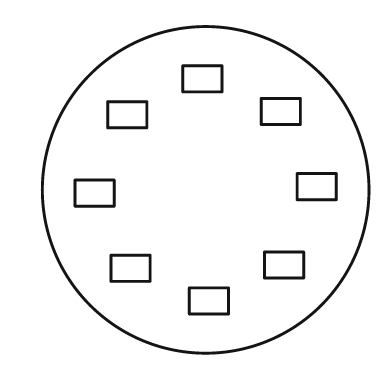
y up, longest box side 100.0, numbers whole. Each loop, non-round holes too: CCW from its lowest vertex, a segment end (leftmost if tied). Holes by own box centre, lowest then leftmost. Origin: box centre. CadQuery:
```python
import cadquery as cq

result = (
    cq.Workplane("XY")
    .moveTo(0.0, 0.0)
    .circle(50.0)
    .moveTo(-5.0, -38.0)
    .lineTo(7.0, -38.0)
    .lineTo(7.0, -30.0)
    .lineTo(-5.0, -30.0)
    .close()
    .moveTo(-29.0, -28.0)
    .lineTo(-17.0, -28.0)
    .lineTo(-17.0, -20.0)
    .lineTo(-29.0, -20.0)
    .close()
    .moveTo(18.0, -27.0)
    .lineTo(30.0, -27.0)
    .lineTo(30.0, -19.0)
    .lineTo(18.0, -19.0)
    .close()
    .moveTo(-40.0, -5.0)
    .lineTo(-28.0, -5.0)
    .lineTo(-28.0, 3.0)
    .lineTo(-40.0, 3.0)
    .close()
    .moveTo(28.0, -3.0)
    .lineTo(40.0, -3.0)
    .lineTo(40.0, 5.0)
    .lineTo(28.0, 5.0)
    .close()
    .moveTo(-30.0, 19.0)
    .lineTo(-18.0, 19.0)
    .lineTo(-18.0, 27.0)
    .lineTo(-30.0, 27.0)
    .close()
    .moveTo(17.0, 20.0)
    .lineTo(29.0, 20.0)
    .lineTo(29.0, 28.0)
    .lineTo(17.0, 28.0)
    .close()
    .moveTo(-7.0, 30.0)
    .lineTo(5.0, 30.0)
    .lineTo(5.0, 38.0)
    .lineTo(-7.0, 38.0)
    .close()
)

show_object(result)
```